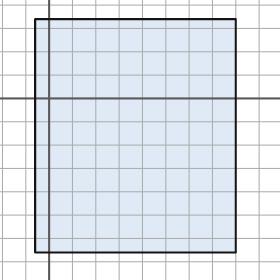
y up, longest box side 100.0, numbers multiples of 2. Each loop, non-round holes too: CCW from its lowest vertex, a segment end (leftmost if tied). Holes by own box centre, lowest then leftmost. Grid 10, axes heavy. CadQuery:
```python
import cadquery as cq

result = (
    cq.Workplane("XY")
    .moveTo(-6.0, -66.0)
    .lineTo(80.0, -66.0)
    .lineTo(80.0, 34.0)
    .lineTo(-6.0, 34.0)
    .close()
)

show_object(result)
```